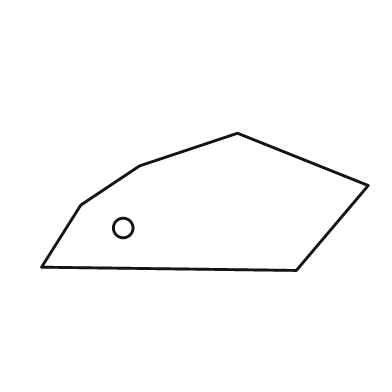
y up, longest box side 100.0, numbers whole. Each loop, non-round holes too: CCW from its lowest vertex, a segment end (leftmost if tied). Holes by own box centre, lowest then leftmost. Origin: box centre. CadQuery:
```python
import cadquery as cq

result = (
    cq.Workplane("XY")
    .moveTo(28.0, -21.0)
    .lineTo(50.0, 5.0)
    .lineTo(10.0, 21.0)
    .lineTo(-20.0, 11.0)
    .lineTo(-38.0, -1.0)
    .lineTo(-50.0, -20.0)
    .close()
    .moveTo(-25.0, -8.0)
    .circle(3.0)
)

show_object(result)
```